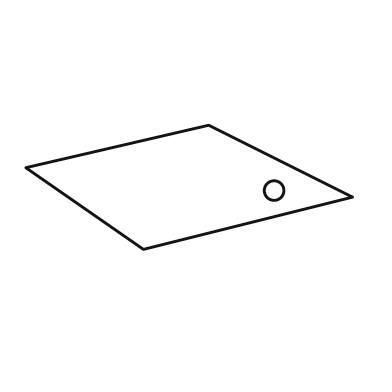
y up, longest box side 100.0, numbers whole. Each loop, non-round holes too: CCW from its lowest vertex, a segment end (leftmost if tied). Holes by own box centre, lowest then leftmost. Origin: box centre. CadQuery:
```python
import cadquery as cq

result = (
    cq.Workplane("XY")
    .moveTo(-14.0, -19.0)
    .lineTo(50.0, -3.0)
    .lineTo(6.0, 19.0)
    .lineTo(-50.0, 6.0)
    .close()
    .moveTo(26.0, -1.0)
    .circle(3.0)
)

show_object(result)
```